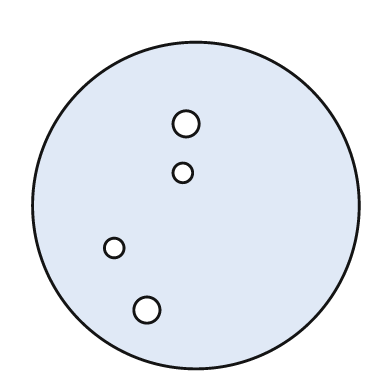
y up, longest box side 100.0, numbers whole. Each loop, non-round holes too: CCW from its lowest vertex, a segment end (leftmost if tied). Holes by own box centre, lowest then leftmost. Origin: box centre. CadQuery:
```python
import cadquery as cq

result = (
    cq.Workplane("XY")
    .moveTo(0.0, 0.0)
    .circle(50.0)
    .moveTo(-15.0, -32.0)
    .circle(4.0)
    .moveTo(-25.0, -13.0)
    .circle(3.0)
    .moveTo(-4.0, 10.0)
    .circle(3.0)
    .moveTo(-3.0, 25.0)
    .circle(4.0)
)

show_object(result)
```